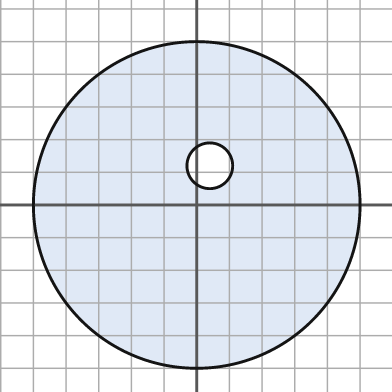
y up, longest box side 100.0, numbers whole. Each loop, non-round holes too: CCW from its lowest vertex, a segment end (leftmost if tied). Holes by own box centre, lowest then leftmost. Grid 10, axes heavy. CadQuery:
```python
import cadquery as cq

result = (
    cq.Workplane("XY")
    .moveTo(0.0, 0.0)
    .circle(50.0)
    .moveTo(4.0, 12.0)
    .circle(7.0)
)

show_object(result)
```